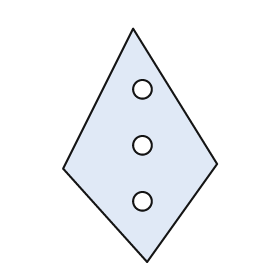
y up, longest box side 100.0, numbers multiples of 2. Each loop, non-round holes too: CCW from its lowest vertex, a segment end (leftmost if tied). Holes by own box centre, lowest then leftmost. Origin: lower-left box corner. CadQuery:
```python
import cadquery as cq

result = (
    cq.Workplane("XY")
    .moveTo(36.0, 0.0)
    .lineTo(66.0, 42.0)
    .lineTo(30.0, 100.0)
    .lineTo(0.0, 40.0)
    .close()
    .moveTo(34.0, 26.0)
    .circle(4.0)
    .moveTo(34.0, 50.0)
    .circle(4.0)
    .moveTo(34.0, 74.0)
    .circle(4.0)
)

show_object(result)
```